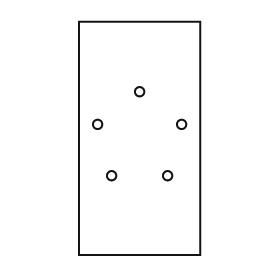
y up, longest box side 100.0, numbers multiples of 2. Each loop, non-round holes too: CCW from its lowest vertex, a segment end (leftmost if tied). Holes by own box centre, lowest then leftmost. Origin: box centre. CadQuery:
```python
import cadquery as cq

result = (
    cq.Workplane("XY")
    .moveTo(-26.0, -50.0)
    .lineTo(26.0, -50.0)
    .lineTo(26.0, 50.0)
    .lineTo(-26.0, 50.0)
    .close()
    .moveTo(-12.0, -16.0)
    .circle(2.0)
    .moveTo(12.0, -16.0)
    .circle(2.0)
    .moveTo(-18.0, 6.0)
    .circle(2.0)
    .moveTo(18.0, 6.0)
    .circle(2.0)
    .moveTo(0.0, 20.0)
    .circle(2.0)
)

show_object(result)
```